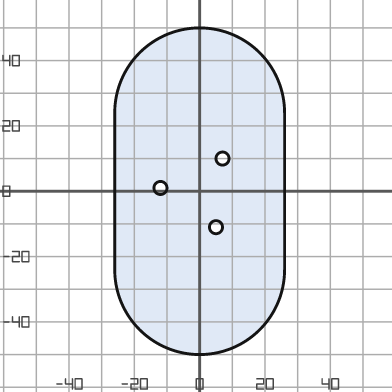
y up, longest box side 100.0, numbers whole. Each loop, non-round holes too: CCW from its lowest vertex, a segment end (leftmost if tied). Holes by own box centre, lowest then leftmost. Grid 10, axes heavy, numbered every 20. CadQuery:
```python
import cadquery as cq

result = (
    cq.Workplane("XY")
    .moveTo(-26.0, -24.0)
    .threePointArc((0.0, -50.0), (26.0, -24.0))
    .lineTo(26.0, 24.0)
    .threePointArc((0.0, 50.0), (-26.0, 24.0))
    .close()
    .moveTo(5.0, -11.0)
    .circle(2.0)
    .moveTo(-12.0, 1.0)
    .circle(2.0)
    .moveTo(7.0, 10.0)
    .circle(2.0)
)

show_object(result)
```